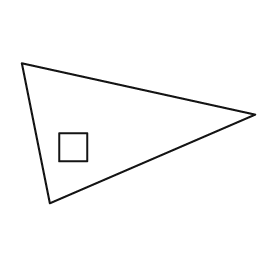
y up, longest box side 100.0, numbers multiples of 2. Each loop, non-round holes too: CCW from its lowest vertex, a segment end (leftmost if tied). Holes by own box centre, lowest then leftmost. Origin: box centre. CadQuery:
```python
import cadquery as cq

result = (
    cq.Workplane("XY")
    .moveTo(-38.0, -30.0)
    .lineTo(50.0, 8.0)
    .lineTo(-50.0, 30.0)
    .close()
    .moveTo(-34.0, -12.0)
    .lineTo(-22.0, -12.0)
    .lineTo(-22.0, 0.0)
    .lineTo(-34.0, 0.0)
    .close()
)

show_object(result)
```